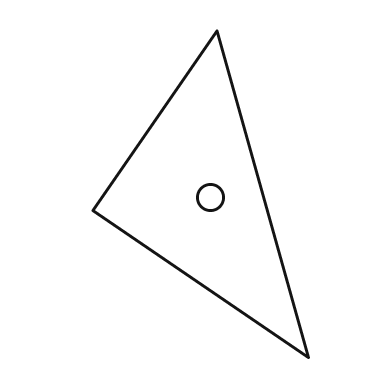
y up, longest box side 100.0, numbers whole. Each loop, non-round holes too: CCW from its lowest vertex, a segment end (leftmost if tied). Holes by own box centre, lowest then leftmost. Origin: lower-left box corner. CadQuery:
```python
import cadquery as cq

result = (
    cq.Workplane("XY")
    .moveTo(66.0, 0.0)
    .lineTo(38.0, 100.0)
    .lineTo(0.0, 45.0)
    .close()
    .moveTo(36.0, 49.0)
    .circle(4.0)
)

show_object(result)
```